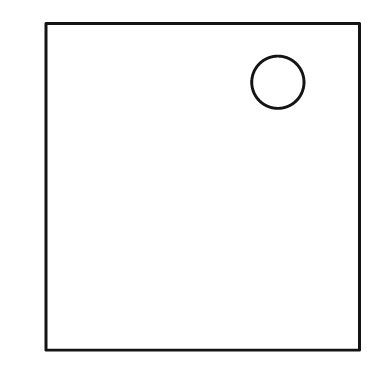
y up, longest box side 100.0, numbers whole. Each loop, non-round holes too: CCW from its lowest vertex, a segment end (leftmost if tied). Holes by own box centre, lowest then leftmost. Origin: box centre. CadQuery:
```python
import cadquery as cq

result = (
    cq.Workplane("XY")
    .moveTo(-48.0, -50.0)
    .lineTo(48.0, -50.0)
    .lineTo(48.0, 50.0)
    .lineTo(-48.0, 50.0)
    .close()
    .moveTo(23.0, 32.0)
    .circle(8.0)
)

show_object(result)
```